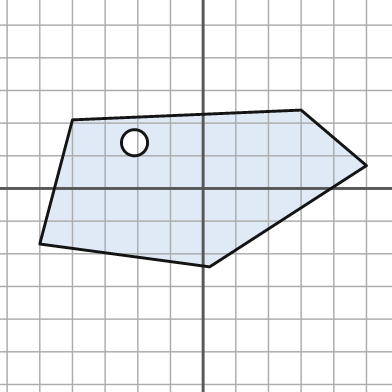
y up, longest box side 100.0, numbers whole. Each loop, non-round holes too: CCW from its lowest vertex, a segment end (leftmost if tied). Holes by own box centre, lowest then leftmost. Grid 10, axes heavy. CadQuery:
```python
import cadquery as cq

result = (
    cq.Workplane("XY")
    .moveTo(2.0, -24.0)
    .lineTo(50.0, 7.0)
    .lineTo(30.0, 24.0)
    .lineTo(-40.0, 21.0)
    .lineTo(-50.0, -17.0)
    .close()
    .moveTo(-21.0, 14.0)
    .circle(4.0)
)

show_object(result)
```